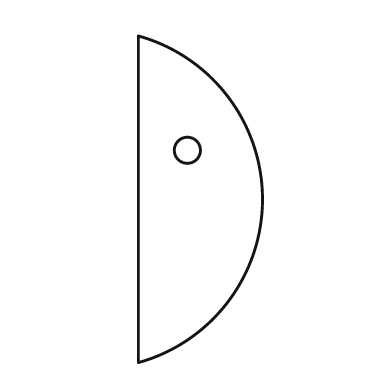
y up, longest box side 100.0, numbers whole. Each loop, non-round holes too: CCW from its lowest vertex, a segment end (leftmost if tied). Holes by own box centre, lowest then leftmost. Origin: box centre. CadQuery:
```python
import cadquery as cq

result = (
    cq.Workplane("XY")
    .moveTo(-19.0, -50.0)
    .threePointArc((19.0, 0.0), (-19.0, 50.0))
    .close()
    .moveTo(-4.0, 15.0)
    .circle(4.0)
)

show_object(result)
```